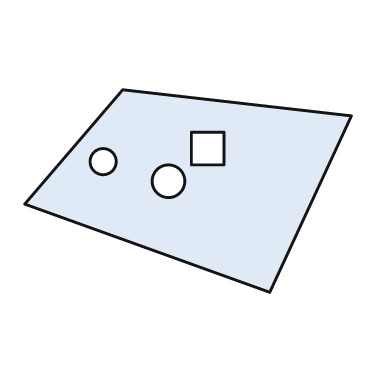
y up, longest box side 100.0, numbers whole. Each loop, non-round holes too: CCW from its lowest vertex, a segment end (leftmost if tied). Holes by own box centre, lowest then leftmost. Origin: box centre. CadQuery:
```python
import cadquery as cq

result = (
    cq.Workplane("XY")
    .moveTo(25.0, -31.0)
    .lineTo(50.0, 23.0)
    .lineTo(-20.0, 31.0)
    .lineTo(-50.0, -4.0)
    .close()
    .moveTo(-6.0, 3.0)
    .circle(5.0)
    .moveTo(-26.0, 9.0)
    .circle(4.0)
    .moveTo(1.0, 8.0)
    .lineTo(11.0, 8.0)
    .lineTo(11.0, 18.0)
    .lineTo(1.0, 18.0)
    .close()
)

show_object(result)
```